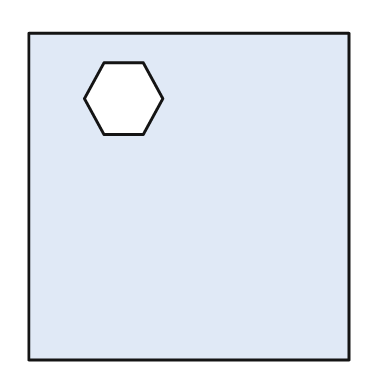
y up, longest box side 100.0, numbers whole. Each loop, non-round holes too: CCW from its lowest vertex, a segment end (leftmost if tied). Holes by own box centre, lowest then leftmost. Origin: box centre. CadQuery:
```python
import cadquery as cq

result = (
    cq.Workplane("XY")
    .moveTo(-49.0, -50.0)
    .lineTo(49.0, -50.0)
    .lineTo(49.0, 50.0)
    .lineTo(-49.0, 50.0)
    .close()
    .moveTo(-26.0, 19.0)
    .lineTo(-14.0, 19.0)
    .lineTo(-8.0, 30.0)
    .lineTo(-14.0, 41.0)
    .lineTo(-26.0, 41.0)
    .lineTo(-32.0, 30.0)
    .close()
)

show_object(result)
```